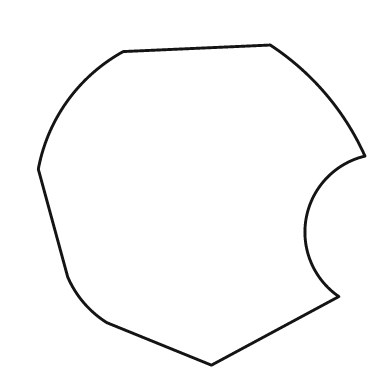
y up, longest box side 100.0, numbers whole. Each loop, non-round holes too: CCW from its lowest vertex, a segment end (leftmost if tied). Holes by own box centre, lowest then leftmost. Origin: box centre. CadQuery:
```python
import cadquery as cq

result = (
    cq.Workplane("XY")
    .moveTo(3.0, -49.0)
    .lineTo(42.0, -28.0)
    .threePointArc((32.0, -4.0), (50.0, 15.0))
    .threePointArc((38.0, 34.0), (21.0, 49.0))
    .lineTo(-24.0, 47.0)
    .threePointArc((-41.0, 32.0), (-50.0, 11.0))
    .lineTo(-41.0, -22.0)
    .threePointArc((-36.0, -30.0), (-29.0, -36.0))
    .close()
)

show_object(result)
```